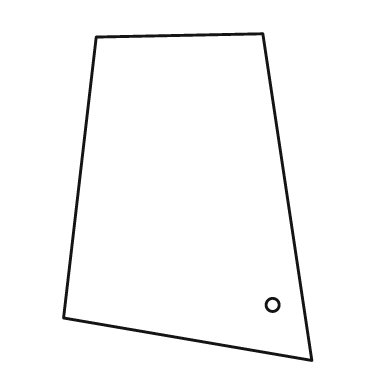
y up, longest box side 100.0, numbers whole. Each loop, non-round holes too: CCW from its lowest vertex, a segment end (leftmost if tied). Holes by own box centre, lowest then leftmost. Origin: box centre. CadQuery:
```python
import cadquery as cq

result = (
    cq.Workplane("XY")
    .moveTo(38.0, -50.0)
    .lineTo(23.0, 50.0)
    .lineTo(-28.0, 49.0)
    .lineTo(-38.0, -37.0)
    .close()
    .moveTo(26.0, -33.0)
    .circle(2.0)
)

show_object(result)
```